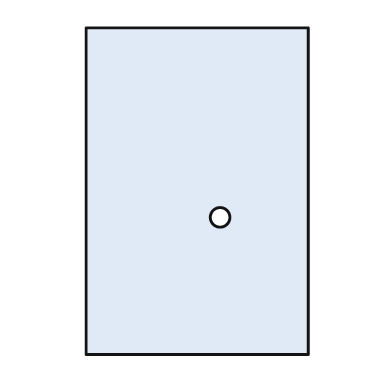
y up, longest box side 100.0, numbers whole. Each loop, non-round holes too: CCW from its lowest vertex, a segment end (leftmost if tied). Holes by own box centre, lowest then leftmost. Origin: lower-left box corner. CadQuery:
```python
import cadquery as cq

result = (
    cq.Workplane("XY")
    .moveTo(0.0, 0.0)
    .lineTo(68.0, 0.0)
    .lineTo(68.0, 100.0)
    .lineTo(0.0, 100.0)
    .close()
    .moveTo(41.0, 42.0)
    .circle(3.0)
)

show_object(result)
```